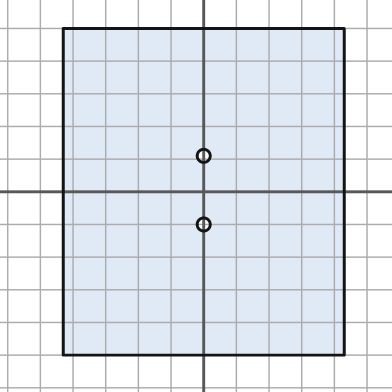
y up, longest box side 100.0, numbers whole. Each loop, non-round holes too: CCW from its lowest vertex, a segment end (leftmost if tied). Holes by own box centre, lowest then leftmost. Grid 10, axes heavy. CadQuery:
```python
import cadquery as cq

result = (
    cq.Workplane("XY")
    .moveTo(-43.0, -50.0)
    .lineTo(43.0, -50.0)
    .lineTo(43.0, 50.0)
    .lineTo(-43.0, 50.0)
    .close()
    .moveTo(0.0, -10.0)
    .circle(2.0)
    .moveTo(0.0, 11.0)
    .circle(2.0)
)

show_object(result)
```